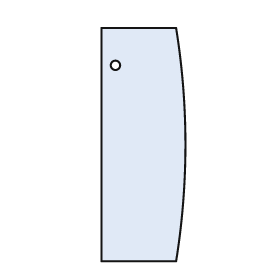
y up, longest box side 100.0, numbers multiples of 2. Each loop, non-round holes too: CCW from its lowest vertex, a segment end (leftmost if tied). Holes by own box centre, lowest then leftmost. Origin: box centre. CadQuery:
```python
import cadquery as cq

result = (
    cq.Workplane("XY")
    .moveTo(-18.0, -50.0)
    .lineTo(14.0, -50.0)
    .threePointArc((18.0, 0.0), (14.0, 50.0))
    .lineTo(-18.0, 50.0)
    .close()
    .moveTo(-12.0, 34.0)
    .circle(2.0)
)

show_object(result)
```